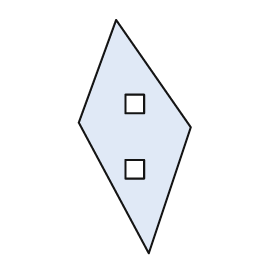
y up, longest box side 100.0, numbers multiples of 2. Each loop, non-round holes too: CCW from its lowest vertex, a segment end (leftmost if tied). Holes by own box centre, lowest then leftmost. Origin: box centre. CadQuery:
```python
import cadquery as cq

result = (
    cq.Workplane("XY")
    .moveTo(6.0, -50.0)
    .lineTo(24.0, 4.0)
    .lineTo(-8.0, 50.0)
    .lineTo(-24.0, 6.0)
    .close()
    .moveTo(-4.0, -18.0)
    .lineTo(4.0, -18.0)
    .lineTo(4.0, -10.0)
    .lineTo(-4.0, -10.0)
    .close()
    .moveTo(-4.0, 10.0)
    .lineTo(4.0, 10.0)
    .lineTo(4.0, 18.0)
    .lineTo(-4.0, 18.0)
    .close()
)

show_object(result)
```